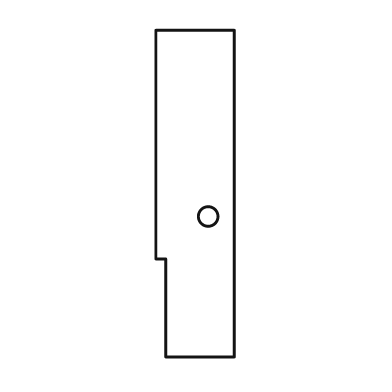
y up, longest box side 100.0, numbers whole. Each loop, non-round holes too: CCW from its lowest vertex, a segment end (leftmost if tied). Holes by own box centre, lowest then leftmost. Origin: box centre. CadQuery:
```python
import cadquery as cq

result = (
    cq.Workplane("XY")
    .moveTo(-9.0, -50.0)
    .lineTo(12.0, -50.0)
    .lineTo(12.0, 50.0)
    .lineTo(-12.0, 50.0)
    .lineTo(-12.0, -20.0)
    .lineTo(-9.0, -20.0)
    .close()
    .moveTo(4.0, -7.0)
    .circle(3.0)
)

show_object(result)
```